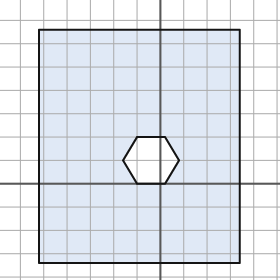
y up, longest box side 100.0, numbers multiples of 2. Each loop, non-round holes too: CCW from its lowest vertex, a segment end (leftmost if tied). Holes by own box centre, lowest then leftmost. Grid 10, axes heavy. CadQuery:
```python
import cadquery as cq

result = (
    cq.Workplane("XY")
    .moveTo(-52.0, -34.0)
    .lineTo(34.0, -34.0)
    .lineTo(34.0, 66.0)
    .lineTo(-52.0, 66.0)
    .close()
    .moveTo(-10.0, 0.0)
    .lineTo(2.0, 0.0)
    .lineTo(8.0, 10.0)
    .lineTo(2.0, 20.0)
    .lineTo(-10.0, 20.0)
    .lineTo(-16.0, 10.0)
    .close()
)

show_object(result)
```